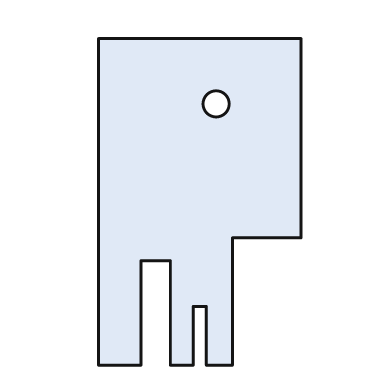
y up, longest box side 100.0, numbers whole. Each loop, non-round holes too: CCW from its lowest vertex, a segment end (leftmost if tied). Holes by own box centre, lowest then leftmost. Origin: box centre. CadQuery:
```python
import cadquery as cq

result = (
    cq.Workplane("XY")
    .moveTo(-31.0, -50.0)
    .lineTo(-18.0, -50.0)
    .lineTo(-18.0, -18.0)
    .lineTo(-9.0, -18.0)
    .lineTo(-9.0, -50.0)
    .lineTo(-2.0, -50.0)
    .lineTo(-2.0, -32.0)
    .lineTo(2.0, -32.0)
    .lineTo(2.0, -50.0)
    .lineTo(10.0, -50.0)
    .lineTo(10.0, -11.0)
    .lineTo(31.0, -11.0)
    .lineTo(31.0, 50.0)
    .lineTo(-31.0, 50.0)
    .close()
    .moveTo(5.0, 30.0)
    .circle(4.0)
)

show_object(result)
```